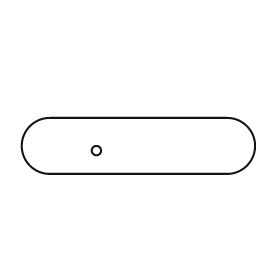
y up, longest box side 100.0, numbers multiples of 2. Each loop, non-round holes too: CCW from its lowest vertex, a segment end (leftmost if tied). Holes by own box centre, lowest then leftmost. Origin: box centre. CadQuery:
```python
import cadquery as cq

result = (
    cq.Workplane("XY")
    .moveTo(-38.0, -12.0)
    .lineTo(38.0, -12.0)
    .threePointArc((50.0, 0.0), (38.0, 12.0))
    .lineTo(-38.0, 12.0)
    .threePointArc((-50.0, 0.0), (-38.0, -12.0))
    .close()
    .moveTo(-18.0, -2.0)
    .circle(2.0)
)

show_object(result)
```